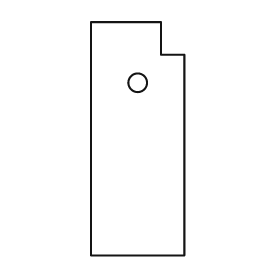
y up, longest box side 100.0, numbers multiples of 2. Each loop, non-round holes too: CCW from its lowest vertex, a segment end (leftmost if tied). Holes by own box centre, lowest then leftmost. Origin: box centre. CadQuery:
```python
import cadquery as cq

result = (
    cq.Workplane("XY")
    .moveTo(-20.0, -50.0)
    .lineTo(20.0, -50.0)
    .lineTo(20.0, 36.0)
    .lineTo(10.0, 36.0)
    .lineTo(10.0, 50.0)
    .lineTo(-20.0, 50.0)
    .close()
    .moveTo(0.0, 24.0)
    .circle(4.0)
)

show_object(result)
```